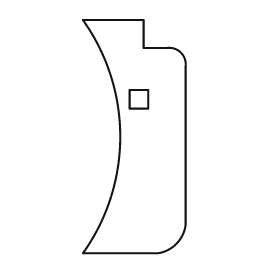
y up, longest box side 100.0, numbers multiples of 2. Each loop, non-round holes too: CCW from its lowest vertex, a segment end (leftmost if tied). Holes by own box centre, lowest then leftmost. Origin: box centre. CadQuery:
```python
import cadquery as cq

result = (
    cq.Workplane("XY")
    .moveTo(-22.0, -50.0)
    .lineTo(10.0, -50.0)
    .threePointArc((18.0, -46.0), (22.0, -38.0))
    .lineTo(22.0, 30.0)
    .threePointArc((20.0, 36.0), (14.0, 38.0))
    .lineTo(4.0, 38.0)
    .lineTo(4.0, 50.0)
    .lineTo(-22.0, 50.0)
    .threePointArc((-6.0, 0.0), (-22.0, -50.0))
    .close()
    .moveTo(-2.0, 12.0)
    .lineTo(6.0, 12.0)
    .lineTo(6.0, 20.0)
    .lineTo(-2.0, 20.0)
    .close()
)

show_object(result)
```